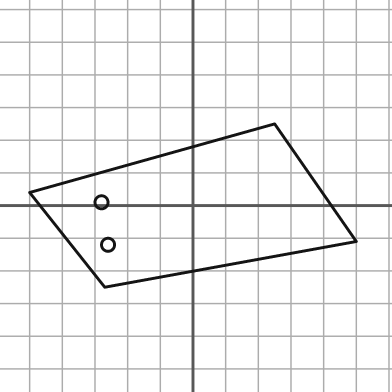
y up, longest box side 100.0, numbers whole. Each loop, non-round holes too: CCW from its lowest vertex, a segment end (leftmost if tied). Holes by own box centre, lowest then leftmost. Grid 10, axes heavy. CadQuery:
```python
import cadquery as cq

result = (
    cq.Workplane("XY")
    .moveTo(-27.0, -25.0)
    .lineTo(50.0, -11.0)
    .lineTo(25.0, 25.0)
    .lineTo(-50.0, 4.0)
    .close()
    .moveTo(-26.0, -12.0)
    .circle(2.0)
    .moveTo(-28.0, 1.0)
    .circle(2.0)
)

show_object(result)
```